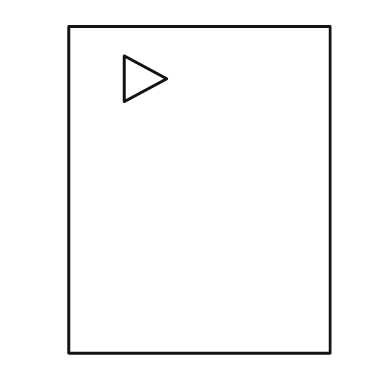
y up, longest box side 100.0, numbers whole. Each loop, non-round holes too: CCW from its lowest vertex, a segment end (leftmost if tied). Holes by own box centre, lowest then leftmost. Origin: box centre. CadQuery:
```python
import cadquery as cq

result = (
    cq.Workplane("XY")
    .moveTo(-40.0, -50.0)
    .lineTo(40.0, -50.0)
    .lineTo(40.0, 50.0)
    .lineTo(-40.0, 50.0)
    .close()
    .moveTo(-23.0, 27.0)
    .lineTo(-10.0, 34.0)
    .lineTo(-23.0, 41.0)
    .close()
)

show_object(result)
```